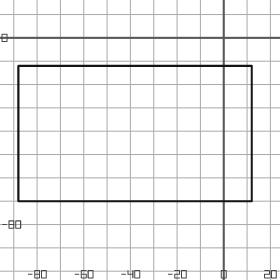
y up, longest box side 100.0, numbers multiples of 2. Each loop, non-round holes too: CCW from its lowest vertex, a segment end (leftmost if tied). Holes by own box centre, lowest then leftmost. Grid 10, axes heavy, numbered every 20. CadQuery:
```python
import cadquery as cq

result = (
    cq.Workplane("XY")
    .moveTo(-88.0, -70.0)
    .lineTo(12.0, -70.0)
    .lineTo(12.0, -12.0)
    .lineTo(-88.0, -12.0)
    .close()
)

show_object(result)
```